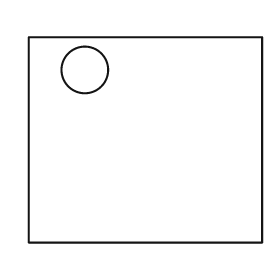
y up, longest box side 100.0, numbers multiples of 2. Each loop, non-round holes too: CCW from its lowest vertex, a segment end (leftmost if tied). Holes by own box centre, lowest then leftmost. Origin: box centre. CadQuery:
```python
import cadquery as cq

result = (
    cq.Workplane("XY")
    .moveTo(-50.0, -44.0)
    .lineTo(50.0, -44.0)
    .lineTo(50.0, 44.0)
    .lineTo(-50.0, 44.0)
    .close()
    .moveTo(-26.0, 30.0)
    .circle(10.0)
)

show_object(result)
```